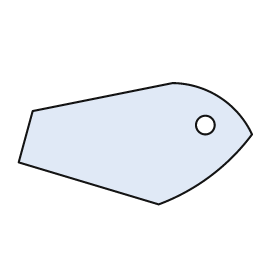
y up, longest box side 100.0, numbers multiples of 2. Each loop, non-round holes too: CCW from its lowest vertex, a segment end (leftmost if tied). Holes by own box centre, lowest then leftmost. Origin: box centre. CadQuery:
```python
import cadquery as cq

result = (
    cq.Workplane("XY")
    .moveTo(10.0, -26.0)
    .threePointArc((32.0, -14.0), (50.0, 4.0))
    .threePointArc((36.0, 20.0), (16.0, 26.0))
    .lineTo(-44.0, 14.0)
    .lineTo(-50.0, -8.0)
    .close()
    .moveTo(30.0, 8.0)
    .circle(4.0)
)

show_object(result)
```